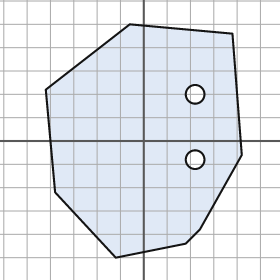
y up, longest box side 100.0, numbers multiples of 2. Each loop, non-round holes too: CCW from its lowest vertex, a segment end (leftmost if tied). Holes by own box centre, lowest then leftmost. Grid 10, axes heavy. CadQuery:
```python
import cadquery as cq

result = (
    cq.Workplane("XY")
    .moveTo(-12.0, -50.0)
    .lineTo(18.0, -44.0)
    .lineTo(24.0, -38.0)
    .lineTo(42.0, -6.0)
    .lineTo(38.0, 46.0)
    .lineTo(-6.0, 50.0)
    .lineTo(-42.0, 22.0)
    .lineTo(-38.0, -22.0)
    .close()
    .moveTo(22.0, -8.0)
    .circle(4.0)
    .moveTo(22.0, 20.0)
    .circle(4.0)
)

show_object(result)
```